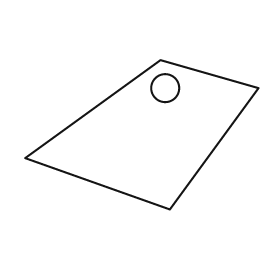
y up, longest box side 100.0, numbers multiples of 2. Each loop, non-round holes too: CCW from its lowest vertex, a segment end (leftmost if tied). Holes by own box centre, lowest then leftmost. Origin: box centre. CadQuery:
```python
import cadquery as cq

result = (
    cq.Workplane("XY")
    .moveTo(12.0, -32.0)
    .lineTo(50.0, 20.0)
    .lineTo(8.0, 32.0)
    .lineTo(-50.0, -10.0)
    .close()
    .moveTo(10.0, 20.0)
    .circle(6.0)
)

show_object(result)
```